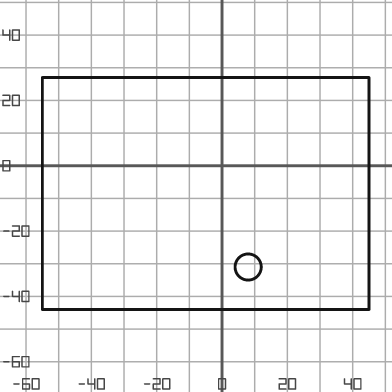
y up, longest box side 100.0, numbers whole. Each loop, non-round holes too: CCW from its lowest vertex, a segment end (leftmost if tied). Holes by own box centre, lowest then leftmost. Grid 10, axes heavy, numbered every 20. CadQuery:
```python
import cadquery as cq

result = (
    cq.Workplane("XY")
    .moveTo(-55.0, -44.0)
    .lineTo(45.0, -44.0)
    .lineTo(45.0, 27.0)
    .lineTo(-55.0, 27.0)
    .close()
    .moveTo(8.0, -31.0)
    .circle(4.0)
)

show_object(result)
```